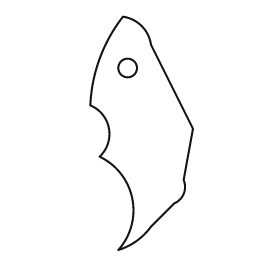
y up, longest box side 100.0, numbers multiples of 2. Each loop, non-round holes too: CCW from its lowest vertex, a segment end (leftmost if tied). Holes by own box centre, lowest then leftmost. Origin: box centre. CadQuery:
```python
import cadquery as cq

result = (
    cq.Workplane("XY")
    .moveTo(-10.0, -50.0)
    .threePointArc((-2.0, -46.0), (4.0, -40.0))
    .lineTo(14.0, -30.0)
    .threePointArc((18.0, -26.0), (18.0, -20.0))
    .lineTo(22.0, 2.0)
    .lineTo(4.0, 38.0)
    .threePointArc((0.0, 46.0), (-8.0, 50.0))
    .threePointArc((-18.0, 32.0), (-22.0, 12.0))
    .threePointArc((-14.0, 2.0), (-18.0, -10.0))
    .threePointArc((-4.0, -28.0), (-10.0, -50.0))
    .close()
    .moveTo(-6.0, 28.0)
    .circle(4.0)
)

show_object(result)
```